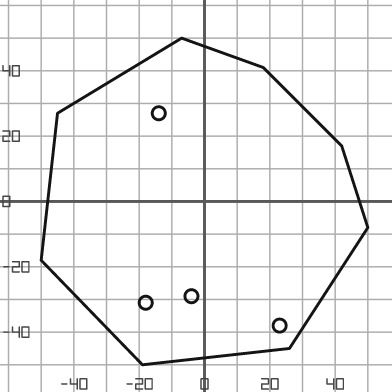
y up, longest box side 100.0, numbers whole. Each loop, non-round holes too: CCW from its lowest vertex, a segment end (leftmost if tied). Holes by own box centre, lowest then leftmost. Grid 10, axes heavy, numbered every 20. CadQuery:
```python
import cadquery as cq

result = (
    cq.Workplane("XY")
    .moveTo(-19.0, -50.0)
    .lineTo(26.0, -45.0)
    .lineTo(50.0, -8.0)
    .lineTo(42.0, 17.0)
    .lineTo(18.0, 41.0)
    .lineTo(-7.0, 50.0)
    .lineTo(-45.0, 27.0)
    .lineTo(-50.0, -18.0)
    .close()
    .moveTo(23.0, -38.0)
    .circle(2.0)
    .moveTo(-18.0, -31.0)
    .circle(2.0)
    .moveTo(-4.0, -29.0)
    .circle(2.0)
    .moveTo(-14.0, 27.0)
    .circle(2.0)
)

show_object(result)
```